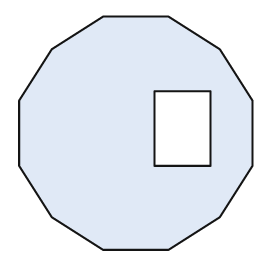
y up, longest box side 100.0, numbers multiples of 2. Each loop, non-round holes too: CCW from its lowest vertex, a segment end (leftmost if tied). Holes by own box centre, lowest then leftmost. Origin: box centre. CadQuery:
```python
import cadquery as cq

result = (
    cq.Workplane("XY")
    .moveTo(-14.0, -50.0)
    .lineTo(14.0, -50.0)
    .lineTo(36.0, -36.0)
    .lineTo(50.0, -14.0)
    .lineTo(50.0, 14.0)
    .lineTo(36.0, 36.0)
    .lineTo(14.0, 50.0)
    .lineTo(-14.0, 50.0)
    .lineTo(-36.0, 36.0)
    .lineTo(-50.0, 14.0)
    .lineTo(-50.0, -14.0)
    .lineTo(-36.0, -36.0)
    .close()
    .moveTo(8.0, -14.0)
    .lineTo(32.0, -14.0)
    .lineTo(32.0, 18.0)
    .lineTo(8.0, 18.0)
    .close()
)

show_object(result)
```